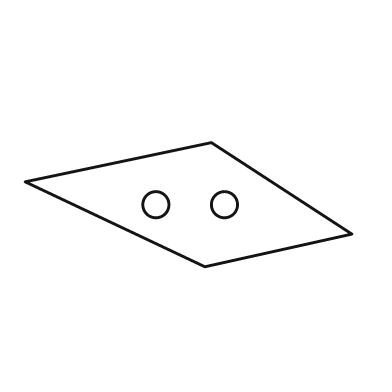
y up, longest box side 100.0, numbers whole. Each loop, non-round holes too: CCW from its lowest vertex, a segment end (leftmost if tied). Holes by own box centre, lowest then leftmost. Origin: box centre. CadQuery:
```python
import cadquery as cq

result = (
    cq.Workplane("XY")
    .moveTo(5.0, -19.0)
    .lineTo(50.0, -9.0)
    .lineTo(7.0, 19.0)
    .lineTo(-50.0, 7.0)
    .close()
    .moveTo(-10.0, 0.0)
    .circle(4.0)
    .moveTo(11.0, 0.0)
    .circle(4.0)
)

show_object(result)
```